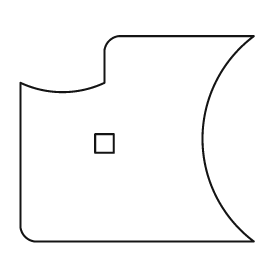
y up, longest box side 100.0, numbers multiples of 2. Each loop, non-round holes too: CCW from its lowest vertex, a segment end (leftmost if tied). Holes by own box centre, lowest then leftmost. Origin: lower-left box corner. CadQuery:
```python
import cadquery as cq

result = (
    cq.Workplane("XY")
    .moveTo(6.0, 0.0)
    .lineTo(100.0, 0.0)
    .threePointArc((78.0, 44.0), (100.0, 88.0))
    .lineTo(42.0, 88.0)
    .threePointArc((38.0, 86.0), (36.0, 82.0))
    .lineTo(36.0, 68.0)
    .threePointArc((18.0, 64.0), (0.0, 68.0))
    .lineTo(0.0, 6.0)
    .threePointArc((2.0, 2.0), (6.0, 0.0))
    .close()
    .moveTo(32.0, 38.0)
    .lineTo(40.0, 38.0)
    .lineTo(40.0, 46.0)
    .lineTo(32.0, 46.0)
    .close()
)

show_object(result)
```